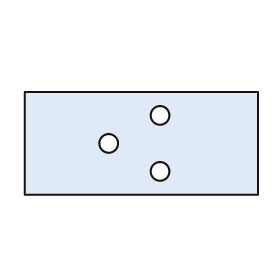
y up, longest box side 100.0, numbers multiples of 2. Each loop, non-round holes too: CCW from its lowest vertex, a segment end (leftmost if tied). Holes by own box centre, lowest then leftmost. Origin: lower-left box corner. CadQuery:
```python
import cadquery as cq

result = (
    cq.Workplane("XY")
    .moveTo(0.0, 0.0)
    .lineTo(100.0, 0.0)
    .lineTo(100.0, 44.0)
    .lineTo(0.0, 44.0)
    .close()
    .moveTo(58.0, 10.0)
    .circle(4.0)
    .moveTo(36.0, 22.0)
    .circle(4.0)
    .moveTo(58.0, 34.0)
    .circle(4.0)
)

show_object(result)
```